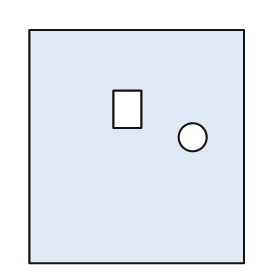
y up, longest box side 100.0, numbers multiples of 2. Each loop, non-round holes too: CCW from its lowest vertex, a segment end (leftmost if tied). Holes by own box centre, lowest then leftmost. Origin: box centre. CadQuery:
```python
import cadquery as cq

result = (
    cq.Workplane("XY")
    .moveTo(-46.0, -50.0)
    .lineTo(46.0, -50.0)
    .lineTo(46.0, 50.0)
    .lineTo(-46.0, 50.0)
    .close()
    .moveTo(24.0, 4.0)
    .circle(6.0)
    .moveTo(-10.0, 8.0)
    .lineTo(2.0, 8.0)
    .lineTo(2.0, 24.0)
    .lineTo(-10.0, 24.0)
    .close()
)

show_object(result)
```